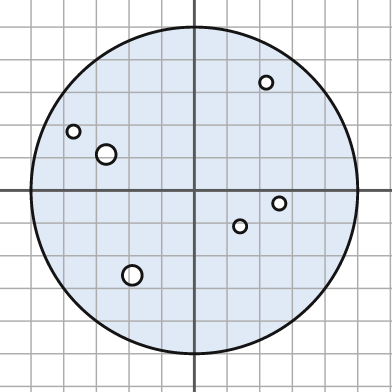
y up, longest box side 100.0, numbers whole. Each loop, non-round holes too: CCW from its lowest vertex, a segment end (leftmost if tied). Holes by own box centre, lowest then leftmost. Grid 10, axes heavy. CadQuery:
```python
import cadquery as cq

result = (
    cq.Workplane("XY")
    .moveTo(0.0, 0.0)
    .circle(50.0)
    .moveTo(-19.0, -26.0)
    .circle(3.0)
    .moveTo(14.0, -11.0)
    .circle(2.0)
    .moveTo(26.0, -4.0)
    .circle(2.0)
    .moveTo(-27.0, 11.0)
    .circle(3.0)
    .moveTo(-37.0, 18.0)
    .circle(2.0)
    .moveTo(22.0, 33.0)
    .circle(2.0)
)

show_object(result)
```